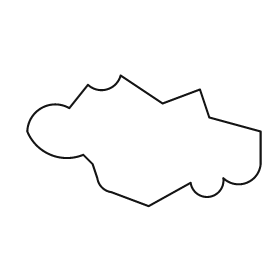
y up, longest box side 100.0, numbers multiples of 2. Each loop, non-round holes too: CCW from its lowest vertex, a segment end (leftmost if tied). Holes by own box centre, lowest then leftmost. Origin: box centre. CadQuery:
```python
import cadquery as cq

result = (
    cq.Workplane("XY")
    .moveTo(2.0, -28.0)
    .lineTo(20.0, -18.0)
    .threePointArc((28.0, -24.0), (34.0, -16.0))
    .threePointArc((44.0, -18.0), (50.0, -10.0))
    .lineTo(50.0, 4.0)
    .lineTo(28.0, 10.0)
    .lineTo(24.0, 22.0)
    .lineTo(8.0, 16.0)
    .lineTo(-10.0, 28.0)
    .threePointArc((-16.0, 22.0), (-24.0, 24.0))
    .lineTo(-32.0, 14.0)
    .threePointArc((-44.0, 14.0), (-50.0, 4.0))
    .threePointArc((-40.0, -6.0), (-26.0, -6.0))
    .lineTo(-22.0, -10.0)
    .lineTo(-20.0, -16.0)
    .threePointArc((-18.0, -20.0), (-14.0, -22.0))
    .close()
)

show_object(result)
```